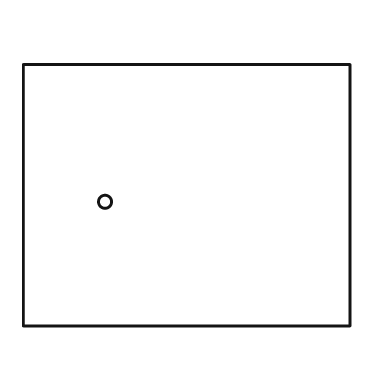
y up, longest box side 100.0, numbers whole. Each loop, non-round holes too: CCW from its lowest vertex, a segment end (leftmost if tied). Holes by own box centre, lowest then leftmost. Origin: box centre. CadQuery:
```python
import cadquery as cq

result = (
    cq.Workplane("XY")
    .moveTo(-50.0, -40.0)
    .lineTo(50.0, -40.0)
    .lineTo(50.0, 40.0)
    .lineTo(-50.0, 40.0)
    .close()
    .moveTo(-25.0, -2.0)
    .circle(2.0)
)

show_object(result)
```